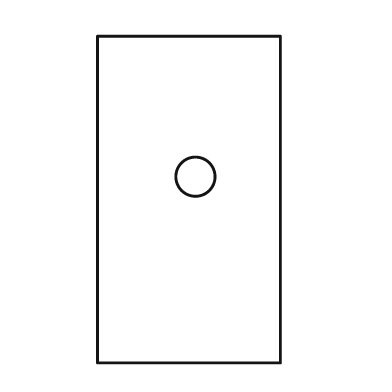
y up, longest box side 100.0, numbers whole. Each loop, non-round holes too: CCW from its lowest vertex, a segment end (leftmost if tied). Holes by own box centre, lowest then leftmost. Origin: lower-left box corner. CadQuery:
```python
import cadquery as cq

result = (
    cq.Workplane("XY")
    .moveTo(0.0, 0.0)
    .lineTo(56.0, 0.0)
    .lineTo(56.0, 100.0)
    .lineTo(0.0, 100.0)
    .close()
    .moveTo(30.0, 57.0)
    .circle(6.0)
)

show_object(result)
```